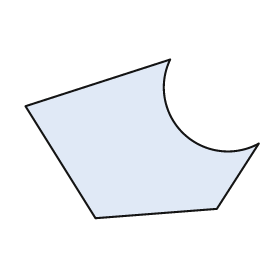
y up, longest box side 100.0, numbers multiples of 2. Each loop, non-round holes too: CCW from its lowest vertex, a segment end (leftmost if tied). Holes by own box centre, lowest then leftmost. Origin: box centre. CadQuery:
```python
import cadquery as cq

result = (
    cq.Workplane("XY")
    .moveTo(-20.0, -34.0)
    .lineTo(32.0, -30.0)
    .lineTo(50.0, -2.0)
    .threePointArc((18.0, 2.0), (12.0, 34.0))
    .lineTo(-50.0, 14.0)
    .close()
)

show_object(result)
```